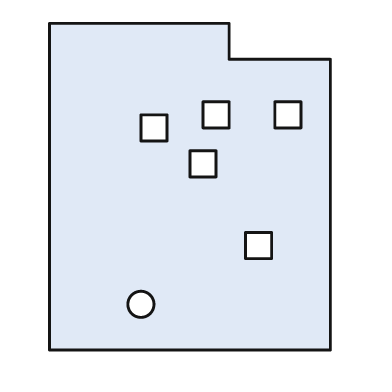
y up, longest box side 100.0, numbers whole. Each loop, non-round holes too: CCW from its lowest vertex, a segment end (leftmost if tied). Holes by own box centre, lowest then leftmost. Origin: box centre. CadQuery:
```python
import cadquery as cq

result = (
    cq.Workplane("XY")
    .moveTo(-43.0, -50.0)
    .lineTo(43.0, -50.0)
    .lineTo(43.0, 39.0)
    .lineTo(12.0, 39.0)
    .lineTo(12.0, 50.0)
    .lineTo(-43.0, 50.0)
    .close()
    .moveTo(-15.0, -36.0)
    .circle(4.0)
    .moveTo(17.0, -22.0)
    .lineTo(25.0, -22.0)
    .lineTo(25.0, -14.0)
    .lineTo(17.0, -14.0)
    .close()
    .moveTo(0.0, 3.0)
    .lineTo(8.0, 3.0)
    .lineTo(8.0, 11.0)
    .lineTo(0.0, 11.0)
    .close()
    .moveTo(-15.0, 14.0)
    .lineTo(-7.0, 14.0)
    .lineTo(-7.0, 22.0)
    .lineTo(-15.0, 22.0)
    .close()
    .moveTo(4.0, 18.0)
    .lineTo(12.0, 18.0)
    .lineTo(12.0, 26.0)
    .lineTo(4.0, 26.0)
    .close()
    .moveTo(26.0, 18.0)
    .lineTo(34.0, 18.0)
    .lineTo(34.0, 26.0)
    .lineTo(26.0, 26.0)
    .close()
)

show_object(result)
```